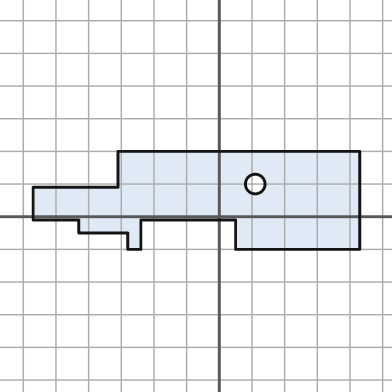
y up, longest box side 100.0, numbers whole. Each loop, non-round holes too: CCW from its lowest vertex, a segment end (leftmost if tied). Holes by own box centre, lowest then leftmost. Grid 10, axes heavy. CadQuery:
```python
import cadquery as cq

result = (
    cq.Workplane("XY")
    .moveTo(-28.0, -10.0)
    .lineTo(-24.0, -10.0)
    .lineTo(-24.0, -1.0)
    .lineTo(5.0, -1.0)
    .lineTo(5.0, -10.0)
    .lineTo(43.0, -10.0)
    .lineTo(43.0, 20.0)
    .lineTo(-31.0, 20.0)
    .lineTo(-31.0, 9.0)
    .lineTo(-57.0, 9.0)
    .lineTo(-57.0, -1.0)
    .lineTo(-43.0, -1.0)
    .lineTo(-43.0, -5.0)
    .lineTo(-28.0, -5.0)
    .close()
    .moveTo(11.0, 10.0)
    .circle(3.0)
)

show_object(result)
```